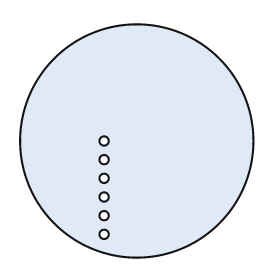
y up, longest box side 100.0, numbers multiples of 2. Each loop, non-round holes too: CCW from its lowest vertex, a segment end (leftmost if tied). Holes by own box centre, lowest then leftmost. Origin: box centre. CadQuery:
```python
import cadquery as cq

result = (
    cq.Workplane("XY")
    .moveTo(0.0, 0.0)
    .circle(50.0)
    .moveTo(-14.0, -40.0)
    .circle(2.0)
    .moveTo(-14.0, -32.0)
    .circle(2.0)
    .moveTo(-14.0, -24.0)
    .circle(2.0)
    .moveTo(-14.0, -16.0)
    .circle(2.0)
    .moveTo(-14.0, -8.0)
    .circle(2.0)
    .moveTo(-14.0, 0.0)
    .circle(2.0)
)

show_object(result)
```